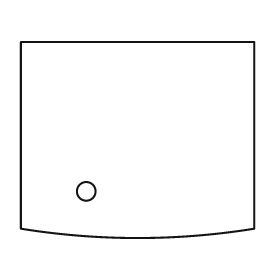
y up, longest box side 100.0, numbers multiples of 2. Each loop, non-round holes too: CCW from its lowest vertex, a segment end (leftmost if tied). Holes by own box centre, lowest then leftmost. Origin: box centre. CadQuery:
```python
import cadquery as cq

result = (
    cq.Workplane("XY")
    .moveTo(-50.0, -38.0)
    .threePointArc((0.0, -42.0), (50.0, -38.0))
    .lineTo(50.0, 42.0)
    .lineTo(-50.0, 42.0)
    .close()
    .moveTo(-22.0, -22.0)
    .circle(4.0)
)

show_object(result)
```